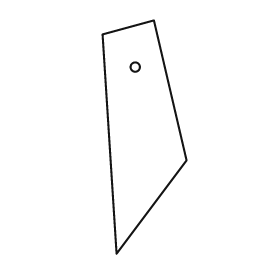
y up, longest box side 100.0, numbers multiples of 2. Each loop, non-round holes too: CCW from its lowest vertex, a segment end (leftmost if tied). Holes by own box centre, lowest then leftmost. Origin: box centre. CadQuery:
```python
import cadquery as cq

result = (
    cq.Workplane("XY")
    .moveTo(-12.0, -50.0)
    .lineTo(18.0, -10.0)
    .lineTo(4.0, 50.0)
    .lineTo(-18.0, 44.0)
    .close()
    .moveTo(-4.0, 30.0)
    .circle(2.0)
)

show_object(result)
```